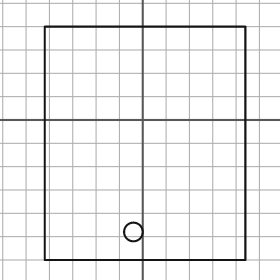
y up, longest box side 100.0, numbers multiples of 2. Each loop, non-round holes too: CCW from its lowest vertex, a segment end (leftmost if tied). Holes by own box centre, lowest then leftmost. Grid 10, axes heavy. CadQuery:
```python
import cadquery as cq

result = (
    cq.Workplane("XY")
    .moveTo(-42.0, -60.0)
    .lineTo(44.0, -60.0)
    .lineTo(44.0, 40.0)
    .lineTo(-42.0, 40.0)
    .close()
    .moveTo(-4.0, -48.0)
    .circle(4.0)
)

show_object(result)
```